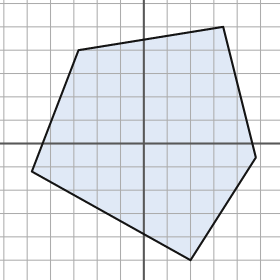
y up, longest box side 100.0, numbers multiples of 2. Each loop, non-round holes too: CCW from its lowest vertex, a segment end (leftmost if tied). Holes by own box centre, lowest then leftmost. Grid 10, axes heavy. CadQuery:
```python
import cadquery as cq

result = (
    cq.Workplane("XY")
    .moveTo(20.0, -50.0)
    .lineTo(48.0, -6.0)
    .lineTo(34.0, 50.0)
    .lineTo(-28.0, 40.0)
    .lineTo(-48.0, -12.0)
    .close()
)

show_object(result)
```